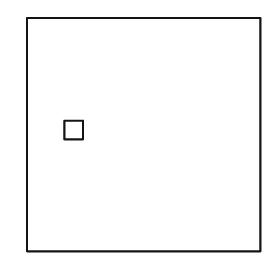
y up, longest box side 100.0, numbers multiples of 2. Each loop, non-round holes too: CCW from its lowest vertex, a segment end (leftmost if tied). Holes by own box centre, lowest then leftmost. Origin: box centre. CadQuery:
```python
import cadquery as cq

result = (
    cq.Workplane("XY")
    .moveTo(-50.0, -50.0)
    .lineTo(50.0, -50.0)
    .lineTo(50.0, 50.0)
    .lineTo(-50.0, 50.0)
    .close()
    .moveTo(-34.0, -2.0)
    .lineTo(-26.0, -2.0)
    .lineTo(-26.0, 6.0)
    .lineTo(-34.0, 6.0)
    .close()
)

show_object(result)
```